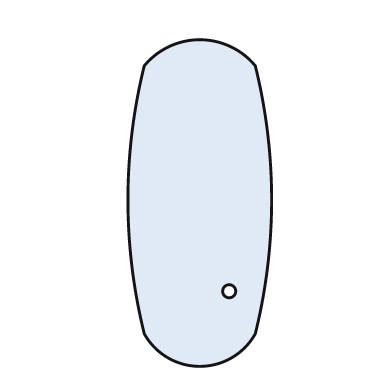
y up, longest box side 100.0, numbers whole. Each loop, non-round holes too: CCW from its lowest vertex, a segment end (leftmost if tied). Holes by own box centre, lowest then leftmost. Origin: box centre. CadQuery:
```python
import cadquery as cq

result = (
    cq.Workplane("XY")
    .moveTo(-17.0, -40.0)
    .threePointArc((0.0, -50.0), (17.0, -40.0))
    .threePointArc((22.0, 1.0), (17.0, 42.0))
    .threePointArc((0.0, 50.0), (-17.0, 42.0))
    .threePointArc((-22.0, 1.0), (-17.0, -40.0))
    .close()
    .moveTo(9.0, -27.0)
    .circle(2.0)
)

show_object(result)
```